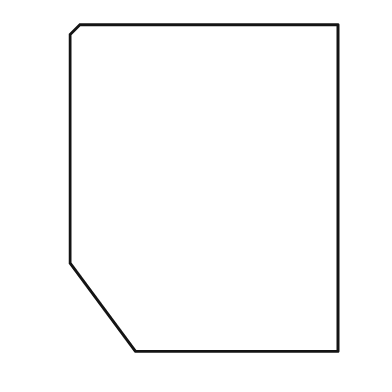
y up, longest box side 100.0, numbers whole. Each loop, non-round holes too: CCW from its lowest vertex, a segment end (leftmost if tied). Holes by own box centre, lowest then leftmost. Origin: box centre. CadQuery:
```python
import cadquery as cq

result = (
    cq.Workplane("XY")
    .moveTo(-21.0, -50.0)
    .lineTo(41.0, -50.0)
    .lineTo(41.0, 50.0)
    .lineTo(-38.0, 50.0)
    .lineTo(-41.0, 47.0)
    .lineTo(-41.0, -23.0)
    .close()
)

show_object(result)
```